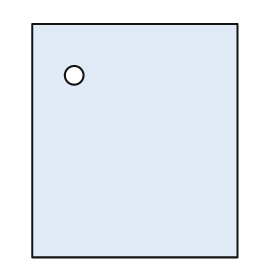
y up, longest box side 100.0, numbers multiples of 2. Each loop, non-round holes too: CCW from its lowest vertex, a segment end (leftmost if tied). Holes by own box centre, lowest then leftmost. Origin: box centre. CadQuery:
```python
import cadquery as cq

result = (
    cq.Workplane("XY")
    .moveTo(-44.0, -50.0)
    .lineTo(44.0, -50.0)
    .lineTo(44.0, 50.0)
    .lineTo(-44.0, 50.0)
    .close()
    .moveTo(-26.0, 28.0)
    .circle(4.0)
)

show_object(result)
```